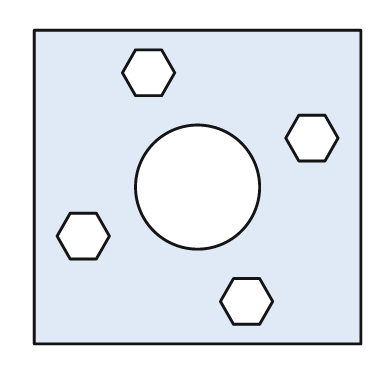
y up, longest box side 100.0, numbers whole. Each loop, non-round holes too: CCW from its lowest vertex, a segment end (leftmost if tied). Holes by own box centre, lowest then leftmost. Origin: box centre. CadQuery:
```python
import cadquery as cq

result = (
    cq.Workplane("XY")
    .moveTo(-50.0, -48.0)
    .lineTo(50.0, -48.0)
    .lineTo(50.0, 48.0)
    .lineTo(-50.0, 48.0)
    .close()
    .moveTo(11.0, -42.0)
    .lineTo(19.0, -42.0)
    .lineTo(23.0, -35.0)
    .lineTo(19.0, -28.0)
    .lineTo(11.0, -28.0)
    .lineTo(7.0, -35.0)
    .close()
    .moveTo(-39.0, -22.0)
    .lineTo(-31.0, -22.0)
    .lineTo(-27.0, -15.0)
    .lineTo(-31.0, -8.0)
    .lineTo(-39.0, -8.0)
    .lineTo(-43.0, -15.0)
    .close()
    .moveTo(0.0, 0.0)
    .circle(19.0)
    .moveTo(31.0, 8.0)
    .lineTo(39.0, 8.0)
    .lineTo(43.0, 15.0)
    .lineTo(39.0, 22.0)
    .lineTo(31.0, 22.0)
    .lineTo(27.0, 15.0)
    .close()
    .moveTo(-19.0, 28.0)
    .lineTo(-11.0, 28.0)
    .lineTo(-7.0, 35.0)
    .lineTo(-11.0, 42.0)
    .lineTo(-19.0, 42.0)
    .lineTo(-23.0, 35.0)
    .close()
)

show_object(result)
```